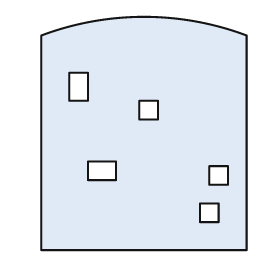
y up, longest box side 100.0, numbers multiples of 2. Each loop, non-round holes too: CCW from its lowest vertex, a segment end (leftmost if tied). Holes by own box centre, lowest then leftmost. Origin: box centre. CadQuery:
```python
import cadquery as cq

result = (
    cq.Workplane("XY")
    .moveTo(-44.0, -50.0)
    .lineTo(44.0, -50.0)
    .lineTo(44.0, 42.0)
    .threePointArc((0.0, 50.0), (-44.0, 42.0))
    .close()
    .moveTo(24.0, -38.0)
    .lineTo(32.0, -38.0)
    .lineTo(32.0, -30.0)
    .lineTo(24.0, -30.0)
    .close()
    .moveTo(28.0, -22.0)
    .lineTo(36.0, -22.0)
    .lineTo(36.0, -14.0)
    .lineTo(28.0, -14.0)
    .close()
    .moveTo(-24.0, -20.0)
    .lineTo(-12.0, -20.0)
    .lineTo(-12.0, -12.0)
    .lineTo(-24.0, -12.0)
    .close()
    .moveTo(-2.0, 6.0)
    .lineTo(6.0, 6.0)
    .lineTo(6.0, 14.0)
    .lineTo(-2.0, 14.0)
    .close()
    .moveTo(-32.0, 14.0)
    .lineTo(-24.0, 14.0)
    .lineTo(-24.0, 26.0)
    .lineTo(-32.0, 26.0)
    .close()
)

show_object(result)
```